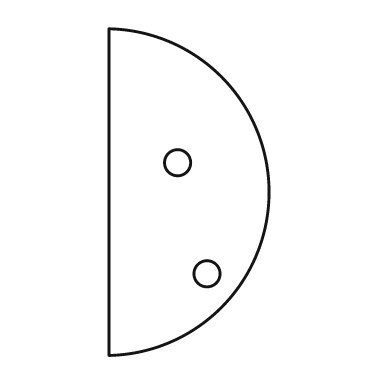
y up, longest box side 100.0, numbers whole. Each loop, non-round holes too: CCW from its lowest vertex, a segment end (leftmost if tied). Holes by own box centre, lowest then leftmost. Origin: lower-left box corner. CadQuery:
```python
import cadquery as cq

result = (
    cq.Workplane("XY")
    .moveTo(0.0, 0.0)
    .threePointArc((49.0, 50.0), (0.0, 100.0))
    .close()
    .moveTo(30.0, 25.0)
    .circle(4.0)
    .moveTo(21.0, 59.0)
    .circle(4.0)
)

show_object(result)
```